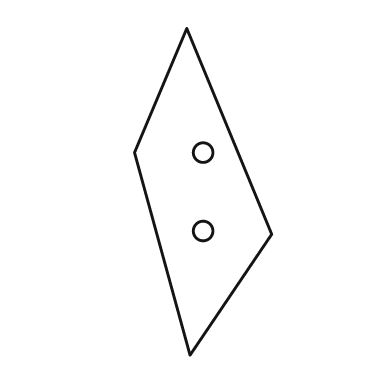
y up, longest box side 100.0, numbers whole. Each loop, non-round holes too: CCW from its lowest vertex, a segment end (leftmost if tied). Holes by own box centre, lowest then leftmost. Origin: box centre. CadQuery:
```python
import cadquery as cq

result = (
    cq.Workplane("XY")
    .moveTo(-4.0, -50.0)
    .lineTo(21.0, -13.0)
    .lineTo(-5.0, 50.0)
    .lineTo(-21.0, 12.0)
    .close()
    .moveTo(0.0, -12.0)
    .circle(3.0)
    .moveTo(0.0, 12.0)
    .circle(3.0)
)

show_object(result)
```